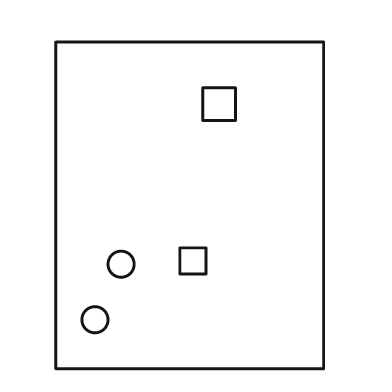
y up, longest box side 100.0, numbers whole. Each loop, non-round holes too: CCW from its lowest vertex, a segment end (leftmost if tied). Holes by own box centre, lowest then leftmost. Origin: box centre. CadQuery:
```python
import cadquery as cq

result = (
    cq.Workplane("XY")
    .moveTo(-41.0, -50.0)
    .lineTo(41.0, -50.0)
    .lineTo(41.0, 50.0)
    .lineTo(-41.0, 50.0)
    .close()
    .moveTo(-29.0, -35.0)
    .circle(4.0)
    .moveTo(-21.0, -18.0)
    .circle(4.0)
    .moveTo(-3.0, -21.0)
    .lineTo(5.0, -21.0)
    .lineTo(5.0, -13.0)
    .lineTo(-3.0, -13.0)
    .close()
    .moveTo(4.0, 26.0)
    .lineTo(14.0, 26.0)
    .lineTo(14.0, 36.0)
    .lineTo(4.0, 36.0)
    .close()
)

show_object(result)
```